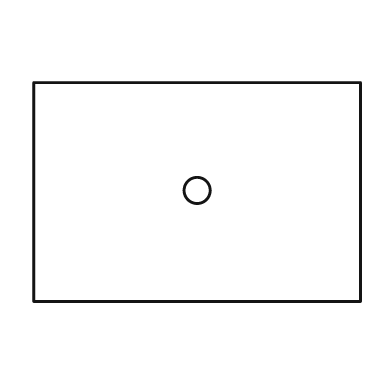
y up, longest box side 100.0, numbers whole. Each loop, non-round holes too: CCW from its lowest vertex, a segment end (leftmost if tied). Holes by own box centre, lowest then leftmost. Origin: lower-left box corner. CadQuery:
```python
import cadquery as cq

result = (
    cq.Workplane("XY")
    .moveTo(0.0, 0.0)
    .lineTo(100.0, 0.0)
    .lineTo(100.0, 67.0)
    .lineTo(0.0, 67.0)
    .close()
    .moveTo(50.0, 34.0)
    .circle(4.0)
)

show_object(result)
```